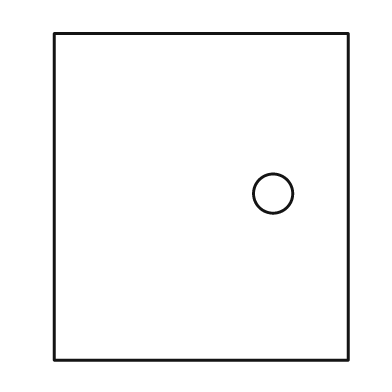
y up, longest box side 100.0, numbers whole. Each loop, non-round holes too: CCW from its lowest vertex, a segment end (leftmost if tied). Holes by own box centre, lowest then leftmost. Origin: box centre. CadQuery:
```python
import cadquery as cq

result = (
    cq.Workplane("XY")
    .moveTo(-45.0, -50.0)
    .lineTo(45.0, -50.0)
    .lineTo(45.0, 50.0)
    .lineTo(-45.0, 50.0)
    .close()
    .moveTo(22.0, 1.0)
    .circle(6.0)
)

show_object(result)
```